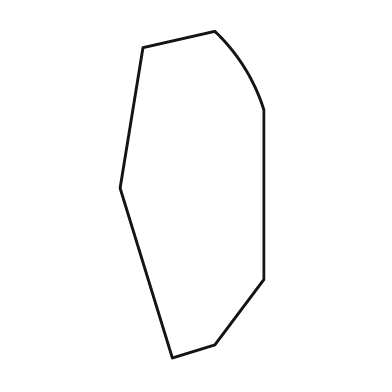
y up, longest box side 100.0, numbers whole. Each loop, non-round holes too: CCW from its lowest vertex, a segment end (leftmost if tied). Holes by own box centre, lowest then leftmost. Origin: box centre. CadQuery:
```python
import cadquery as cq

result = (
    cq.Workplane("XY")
    .moveTo(-6.0, -50.0)
    .lineTo(7.0, -46.0)
    .lineTo(22.0, -26.0)
    .lineTo(22.0, 26.0)
    .threePointArc((16.0, 39.0), (7.0, 50.0))
    .lineTo(-15.0, 45.0)
    .lineTo(-22.0, 2.0)
    .close()
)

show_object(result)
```